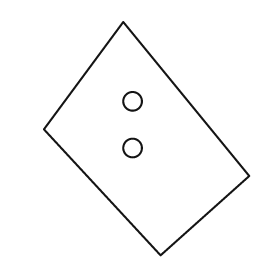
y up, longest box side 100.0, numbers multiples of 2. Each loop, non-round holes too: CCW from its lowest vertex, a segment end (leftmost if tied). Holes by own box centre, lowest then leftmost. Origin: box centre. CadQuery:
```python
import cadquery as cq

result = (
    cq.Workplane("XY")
    .moveTo(6.0, -50.0)
    .lineTo(44.0, -16.0)
    .lineTo(-10.0, 50.0)
    .lineTo(-44.0, 4.0)
    .close()
    .moveTo(-6.0, -4.0)
    .circle(4.0)
    .moveTo(-6.0, 16.0)
    .circle(4.0)
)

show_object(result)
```